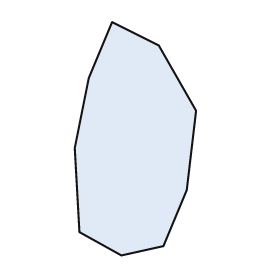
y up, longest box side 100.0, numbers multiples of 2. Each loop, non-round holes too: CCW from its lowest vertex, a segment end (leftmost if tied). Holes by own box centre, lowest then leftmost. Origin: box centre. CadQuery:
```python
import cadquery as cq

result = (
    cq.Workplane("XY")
    .moveTo(-6.0, -50.0)
    .lineTo(12.0, -46.0)
    .lineTo(22.0, -22.0)
    .lineTo(26.0, 12.0)
    .lineTo(10.0, 40.0)
    .lineTo(-10.0, 50.0)
    .lineTo(-20.0, 26.0)
    .lineTo(-26.0, -4.0)
    .lineTo(-24.0, -40.0)
    .close()
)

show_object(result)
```